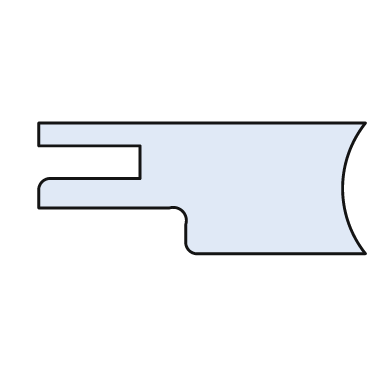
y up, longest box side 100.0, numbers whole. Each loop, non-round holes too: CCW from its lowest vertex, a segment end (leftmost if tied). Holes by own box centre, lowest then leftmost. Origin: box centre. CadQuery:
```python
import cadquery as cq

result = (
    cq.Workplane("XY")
    .moveTo(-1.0, -20.0)
    .lineTo(50.0, -20.0)
    .threePointArc((43.0, 0.0), (50.0, 20.0))
    .lineTo(-50.0, 20.0)
    .lineTo(-50.0, 13.0)
    .lineTo(-19.0, 13.0)
    .lineTo(-19.0, 3.0)
    .lineTo(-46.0, 3.0)
    .threePointArc((-49.0, 2.0), (-50.0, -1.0))
    .lineTo(-50.0, -6.0)
    .lineTo(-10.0, -6.0)
    .threePointArc((-6.0, -7.0), (-5.0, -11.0))
    .lineTo(-5.0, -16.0)
    .threePointArc((-4.0, -19.0), (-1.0, -20.0))
    .close()
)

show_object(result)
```